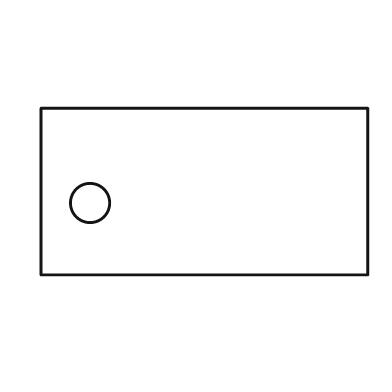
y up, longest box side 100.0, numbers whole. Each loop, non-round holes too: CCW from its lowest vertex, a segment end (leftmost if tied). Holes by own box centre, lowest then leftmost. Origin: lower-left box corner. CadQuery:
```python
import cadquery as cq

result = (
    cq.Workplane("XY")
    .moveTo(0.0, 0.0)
    .lineTo(100.0, 0.0)
    .lineTo(100.0, 51.0)
    .lineTo(0.0, 51.0)
    .close()
    .moveTo(15.0, 22.0)
    .circle(6.0)
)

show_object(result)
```